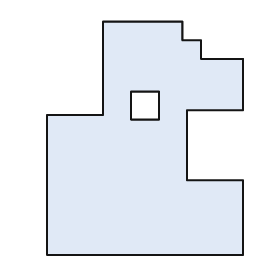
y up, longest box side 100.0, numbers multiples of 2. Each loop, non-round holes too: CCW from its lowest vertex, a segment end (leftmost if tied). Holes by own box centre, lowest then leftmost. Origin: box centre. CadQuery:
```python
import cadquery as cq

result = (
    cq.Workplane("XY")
    .moveTo(-42.0, -50.0)
    .lineTo(42.0, -50.0)
    .lineTo(42.0, -18.0)
    .lineTo(18.0, -18.0)
    .lineTo(18.0, 12.0)
    .lineTo(42.0, 12.0)
    .lineTo(42.0, 34.0)
    .lineTo(24.0, 34.0)
    .lineTo(24.0, 42.0)
    .lineTo(16.0, 42.0)
    .lineTo(16.0, 50.0)
    .lineTo(-18.0, 50.0)
    .lineTo(-18.0, 10.0)
    .lineTo(-42.0, 10.0)
    .close()
    .moveTo(-6.0, 8.0)
    .lineTo(6.0, 8.0)
    .lineTo(6.0, 20.0)
    .lineTo(-6.0, 20.0)
    .close()
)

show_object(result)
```